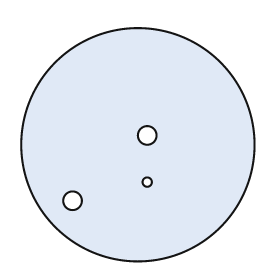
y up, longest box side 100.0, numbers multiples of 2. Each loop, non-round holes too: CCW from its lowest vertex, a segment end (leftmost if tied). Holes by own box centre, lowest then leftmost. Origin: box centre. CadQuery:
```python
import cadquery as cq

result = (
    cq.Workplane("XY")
    .moveTo(0.0, 0.0)
    .circle(50.0)
    .moveTo(-28.0, -24.0)
    .circle(4.0)
    .moveTo(4.0, -16.0)
    .circle(2.0)
    .moveTo(4.0, 4.0)
    .circle(4.0)
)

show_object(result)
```